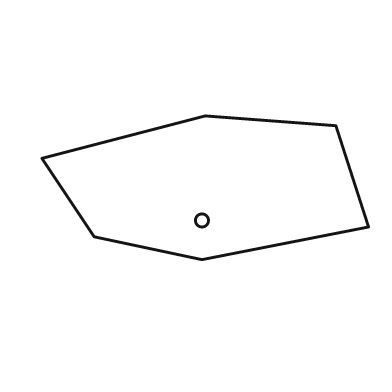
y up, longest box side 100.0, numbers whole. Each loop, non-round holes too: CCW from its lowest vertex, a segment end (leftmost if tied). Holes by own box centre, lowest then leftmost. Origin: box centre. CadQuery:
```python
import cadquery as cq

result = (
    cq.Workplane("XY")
    .moveTo(-1.0, -22.0)
    .lineTo(50.0, -12.0)
    .lineTo(40.0, 19.0)
    .lineTo(0.0, 22.0)
    .lineTo(-50.0, 9.0)
    .lineTo(-34.0, -15.0)
    .close()
    .moveTo(-1.0, -10.0)
    .circle(2.0)
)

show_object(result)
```